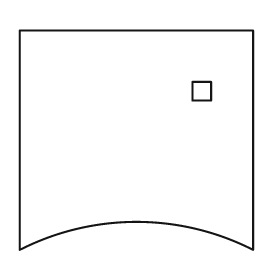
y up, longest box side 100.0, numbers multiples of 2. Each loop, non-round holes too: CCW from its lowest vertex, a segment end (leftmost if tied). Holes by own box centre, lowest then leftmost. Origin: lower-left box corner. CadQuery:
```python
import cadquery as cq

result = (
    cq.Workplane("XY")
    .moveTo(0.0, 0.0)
    .threePointArc((50.0, 12.0), (100.0, 0.0))
    .lineTo(100.0, 94.0)
    .lineTo(0.0, 94.0)
    .close()
    .moveTo(74.0, 64.0)
    .lineTo(82.0, 64.0)
    .lineTo(82.0, 72.0)
    .lineTo(74.0, 72.0)
    .close()
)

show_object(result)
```